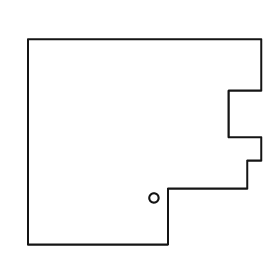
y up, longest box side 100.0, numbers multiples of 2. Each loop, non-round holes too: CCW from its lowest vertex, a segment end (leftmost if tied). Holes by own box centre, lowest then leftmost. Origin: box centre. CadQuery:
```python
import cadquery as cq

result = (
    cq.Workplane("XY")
    .moveTo(-50.0, -44.0)
    .lineTo(10.0, -44.0)
    .lineTo(10.0, -20.0)
    .lineTo(44.0, -20.0)
    .lineTo(44.0, -8.0)
    .lineTo(50.0, -8.0)
    .lineTo(50.0, 2.0)
    .lineTo(36.0, 2.0)
    .lineTo(36.0, 22.0)
    .lineTo(50.0, 22.0)
    .lineTo(50.0, 44.0)
    .lineTo(-50.0, 44.0)
    .close()
    .moveTo(4.0, -24.0)
    .circle(2.0)
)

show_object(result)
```